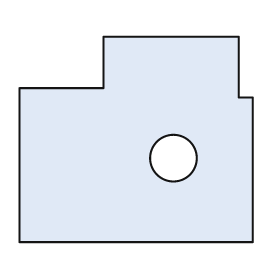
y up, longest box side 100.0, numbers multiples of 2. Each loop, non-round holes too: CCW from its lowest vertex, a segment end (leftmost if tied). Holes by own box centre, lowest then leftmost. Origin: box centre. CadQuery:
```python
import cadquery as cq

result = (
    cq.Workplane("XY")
    .moveTo(-50.0, -44.0)
    .lineTo(50.0, -44.0)
    .lineTo(50.0, 18.0)
    .lineTo(44.0, 18.0)
    .lineTo(44.0, 44.0)
    .lineTo(-14.0, 44.0)
    .lineTo(-14.0, 22.0)
    .lineTo(-50.0, 22.0)
    .close()
    .moveTo(16.0, -8.0)
    .circle(10.0)
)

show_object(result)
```